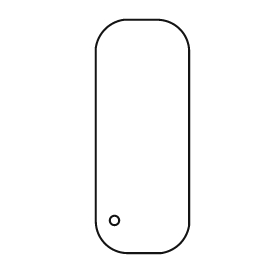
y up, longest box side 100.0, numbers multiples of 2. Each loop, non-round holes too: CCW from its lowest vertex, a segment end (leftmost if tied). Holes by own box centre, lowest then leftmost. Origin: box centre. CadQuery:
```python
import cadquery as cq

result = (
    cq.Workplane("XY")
    .moveTo(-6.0, -50.0)
    .lineTo(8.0, -50.0)
    .threePointArc((16.0, -46.0), (20.0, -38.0))
    .lineTo(20.0, 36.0)
    .threePointArc((16.0, 46.0), (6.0, 50.0))
    .lineTo(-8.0, 50.0)
    .threePointArc((-16.0, 46.0), (-20.0, 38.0))
    .lineTo(-20.0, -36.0)
    .threePointArc((-16.0, -46.0), (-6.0, -50.0))
    .close()
    .moveTo(-12.0, -36.0)
    .circle(2.0)
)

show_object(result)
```